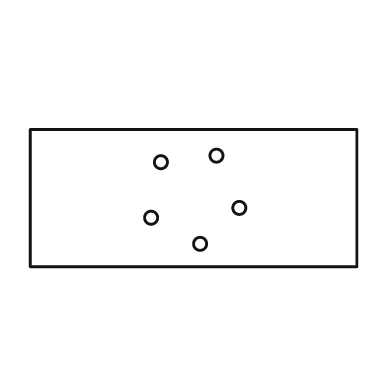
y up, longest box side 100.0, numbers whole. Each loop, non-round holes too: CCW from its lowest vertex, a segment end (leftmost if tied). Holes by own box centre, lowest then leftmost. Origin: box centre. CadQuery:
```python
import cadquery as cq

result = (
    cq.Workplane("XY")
    .moveTo(-50.0, -21.0)
    .lineTo(50.0, -21.0)
    .lineTo(50.0, 21.0)
    .lineTo(-50.0, 21.0)
    .close()
    .moveTo(2.0, -14.0)
    .circle(2.0)
    .moveTo(-13.0, -6.0)
    .circle(2.0)
    .moveTo(14.0, -3.0)
    .circle(2.0)
    .moveTo(-10.0, 11.0)
    .circle(2.0)
    .moveTo(7.0, 13.0)
    .circle(2.0)
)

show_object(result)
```